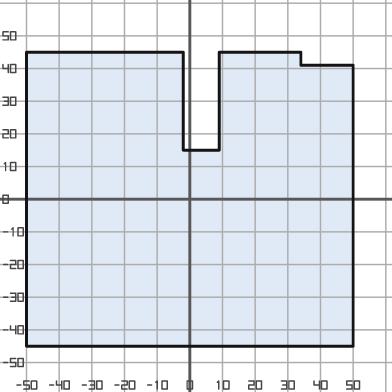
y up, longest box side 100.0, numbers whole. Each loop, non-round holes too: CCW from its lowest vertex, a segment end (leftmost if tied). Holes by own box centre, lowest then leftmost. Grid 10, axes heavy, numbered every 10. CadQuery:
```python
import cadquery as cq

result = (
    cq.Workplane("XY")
    .moveTo(-50.0, -45.0)
    .lineTo(50.0, -45.0)
    .lineTo(50.0, 41.0)
    .lineTo(34.0, 41.0)
    .lineTo(34.0, 45.0)
    .lineTo(9.0, 45.0)
    .lineTo(9.0, 15.0)
    .lineTo(-2.0, 15.0)
    .lineTo(-2.0, 45.0)
    .lineTo(-50.0, 45.0)
    .close()
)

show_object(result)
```